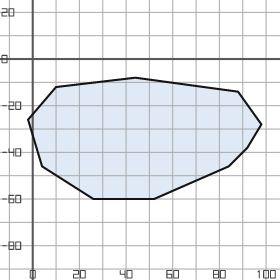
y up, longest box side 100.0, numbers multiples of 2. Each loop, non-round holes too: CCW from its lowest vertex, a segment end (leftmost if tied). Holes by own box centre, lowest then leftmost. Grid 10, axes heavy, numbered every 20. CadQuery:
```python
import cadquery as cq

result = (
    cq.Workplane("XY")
    .moveTo(26.0, -60.0)
    .lineTo(52.0, -60.0)
    .lineTo(84.0, -46.0)
    .lineTo(92.0, -38.0)
    .lineTo(98.0, -28.0)
    .lineTo(88.0, -14.0)
    .lineTo(44.0, -8.0)
    .lineTo(10.0, -12.0)
    .lineTo(-2.0, -26.0)
    .lineTo(4.0, -46.0)
    .close()
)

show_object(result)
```